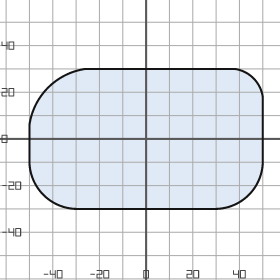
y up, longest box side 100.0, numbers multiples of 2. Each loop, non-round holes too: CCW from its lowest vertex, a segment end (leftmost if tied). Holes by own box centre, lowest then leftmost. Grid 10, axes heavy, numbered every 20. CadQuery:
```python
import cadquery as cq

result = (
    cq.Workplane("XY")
    .moveTo(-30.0, -30.0)
    .lineTo(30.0, -30.0)
    .threePointArc((44.0, -24.0), (50.0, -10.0))
    .lineTo(50.0, 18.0)
    .threePointArc((46.0, 26.0), (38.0, 30.0))
    .lineTo(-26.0, 30.0)
    .threePointArc((-42.0, 22.0), (-50.0, 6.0))
    .lineTo(-50.0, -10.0)
    .threePointArc((-44.0, -24.0), (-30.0, -30.0))
    .close()
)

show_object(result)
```